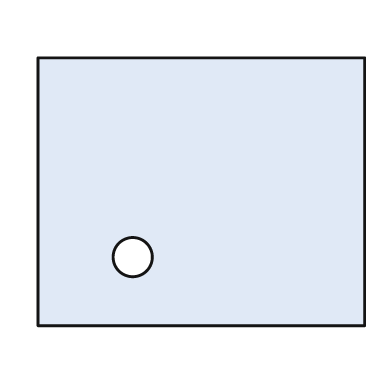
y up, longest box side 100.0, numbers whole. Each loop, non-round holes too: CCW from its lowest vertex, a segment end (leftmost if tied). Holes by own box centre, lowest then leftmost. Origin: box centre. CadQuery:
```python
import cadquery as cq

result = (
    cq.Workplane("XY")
    .moveTo(-50.0, -41.0)
    .lineTo(50.0, -41.0)
    .lineTo(50.0, 41.0)
    .lineTo(-50.0, 41.0)
    .close()
    .moveTo(-21.0, -20.0)
    .circle(6.0)
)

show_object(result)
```